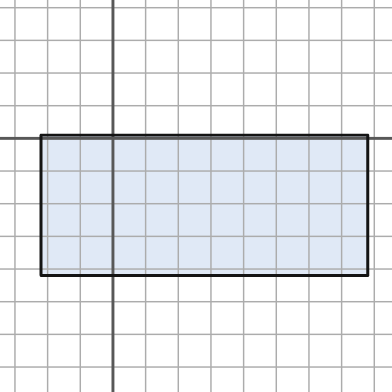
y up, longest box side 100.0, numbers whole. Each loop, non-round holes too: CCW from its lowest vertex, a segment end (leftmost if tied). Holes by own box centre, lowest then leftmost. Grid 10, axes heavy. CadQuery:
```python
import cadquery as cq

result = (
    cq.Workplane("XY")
    .moveTo(-22.0, -42.0)
    .lineTo(78.0, -42.0)
    .lineTo(78.0, 1.0)
    .lineTo(-22.0, 1.0)
    .close()
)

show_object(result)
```